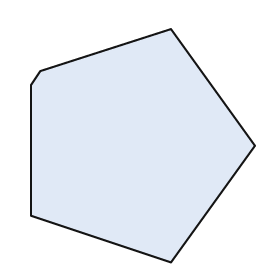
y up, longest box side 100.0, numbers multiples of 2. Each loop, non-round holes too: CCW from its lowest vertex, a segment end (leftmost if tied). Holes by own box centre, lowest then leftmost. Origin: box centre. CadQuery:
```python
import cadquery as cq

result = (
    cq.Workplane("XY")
    .moveTo(12.0, -50.0)
    .lineTo(48.0, 0.0)
    .lineTo(12.0, 50.0)
    .lineTo(-44.0, 32.0)
    .lineTo(-48.0, 26.0)
    .lineTo(-48.0, -30.0)
    .close()
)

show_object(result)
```